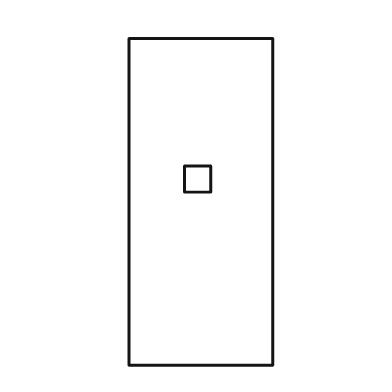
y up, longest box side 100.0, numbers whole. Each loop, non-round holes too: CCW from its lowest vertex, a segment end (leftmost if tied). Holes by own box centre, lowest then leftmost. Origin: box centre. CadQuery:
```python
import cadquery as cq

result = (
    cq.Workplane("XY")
    .moveTo(-22.0, -50.0)
    .lineTo(22.0, -50.0)
    .lineTo(22.0, 50.0)
    .lineTo(-22.0, 50.0)
    .close()
    .moveTo(-5.0, 3.0)
    .lineTo(3.0, 3.0)
    .lineTo(3.0, 11.0)
    .lineTo(-5.0, 11.0)
    .close()
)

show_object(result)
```